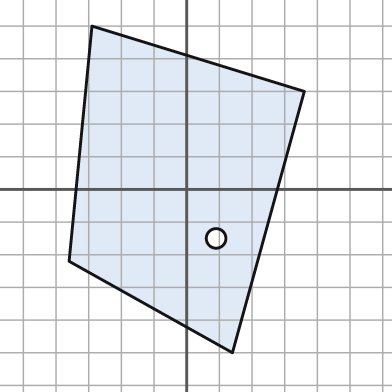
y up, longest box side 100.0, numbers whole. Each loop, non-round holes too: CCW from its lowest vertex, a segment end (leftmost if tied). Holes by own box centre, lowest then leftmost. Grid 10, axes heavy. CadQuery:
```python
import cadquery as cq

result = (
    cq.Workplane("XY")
    .moveTo(14.0, -50.0)
    .lineTo(36.0, 30.0)
    .lineTo(-29.0, 50.0)
    .lineTo(-36.0, -22.0)
    .close()
    .moveTo(9.0, -15.0)
    .circle(3.0)
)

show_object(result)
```